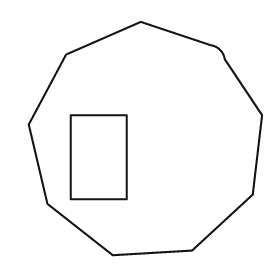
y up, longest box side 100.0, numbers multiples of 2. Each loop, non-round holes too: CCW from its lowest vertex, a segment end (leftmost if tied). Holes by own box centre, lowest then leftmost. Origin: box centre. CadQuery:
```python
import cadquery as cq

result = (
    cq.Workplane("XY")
    .moveTo(-14.0, -50.0)
    .lineTo(20.0, -48.0)
    .lineTo(46.0, -24.0)
    .lineTo(50.0, 10.0)
    .lineTo(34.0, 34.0)
    .threePointArc((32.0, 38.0), (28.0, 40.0))
    .lineTo(-2.0, 50.0)
    .lineTo(-34.0, 36.0)
    .lineTo(-50.0, 6.0)
    .lineTo(-42.0, -28.0)
    .close()
    .moveTo(-32.0, -26.0)
    .lineTo(-8.0, -26.0)
    .lineTo(-8.0, 10.0)
    .lineTo(-32.0, 10.0)
    .close()
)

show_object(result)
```